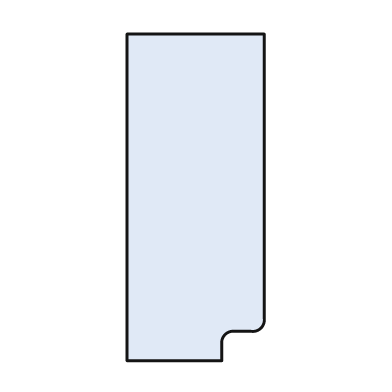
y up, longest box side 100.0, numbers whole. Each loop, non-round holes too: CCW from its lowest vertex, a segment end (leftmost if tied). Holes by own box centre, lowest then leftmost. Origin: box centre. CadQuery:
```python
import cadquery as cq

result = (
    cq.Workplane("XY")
    .moveTo(-21.0, -50.0)
    .lineTo(8.0, -50.0)
    .lineTo(8.0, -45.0)
    .threePointArc((9.0, -42.0), (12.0, -41.0))
    .lineTo(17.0, -41.0)
    .threePointArc((20.0, -40.0), (21.0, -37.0))
    .lineTo(21.0, 50.0)
    .lineTo(-21.0, 50.0)
    .close()
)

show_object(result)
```